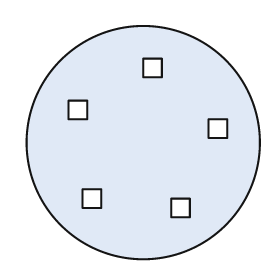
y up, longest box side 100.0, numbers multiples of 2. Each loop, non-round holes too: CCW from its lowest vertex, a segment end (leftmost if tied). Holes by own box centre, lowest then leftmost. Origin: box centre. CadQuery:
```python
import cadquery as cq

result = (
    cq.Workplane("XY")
    .moveTo(0.0, 0.0)
    .circle(50.0)
    .moveTo(12.0, -32.0)
    .lineTo(20.0, -32.0)
    .lineTo(20.0, -24.0)
    .lineTo(12.0, -24.0)
    .close()
    .moveTo(-26.0, -28.0)
    .lineTo(-18.0, -28.0)
    .lineTo(-18.0, -20.0)
    .lineTo(-26.0, -20.0)
    .close()
    .moveTo(28.0, 2.0)
    .lineTo(36.0, 2.0)
    .lineTo(36.0, 10.0)
    .lineTo(28.0, 10.0)
    .close()
    .moveTo(-32.0, 10.0)
    .lineTo(-24.0, 10.0)
    .lineTo(-24.0, 18.0)
    .lineTo(-32.0, 18.0)
    .close()
    .moveTo(0.0, 28.0)
    .lineTo(8.0, 28.0)
    .lineTo(8.0, 36.0)
    .lineTo(0.0, 36.0)
    .close()
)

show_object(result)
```